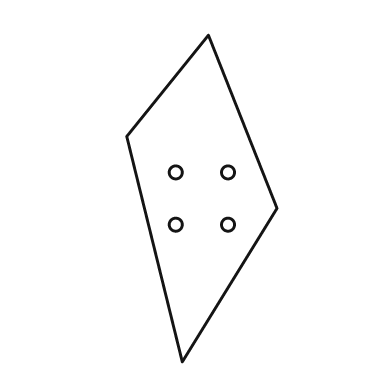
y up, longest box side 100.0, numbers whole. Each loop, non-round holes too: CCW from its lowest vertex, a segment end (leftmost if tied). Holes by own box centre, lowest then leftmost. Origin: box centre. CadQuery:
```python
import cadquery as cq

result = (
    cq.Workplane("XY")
    .moveTo(-6.0, -50.0)
    .lineTo(23.0, -3.0)
    .lineTo(2.0, 50.0)
    .lineTo(-23.0, 19.0)
    .close()
    .moveTo(-8.0, -8.0)
    .circle(2.0)
    .moveTo(8.0, -8.0)
    .circle(2.0)
    .moveTo(-8.0, 8.0)
    .circle(2.0)
    .moveTo(8.0, 8.0)
    .circle(2.0)
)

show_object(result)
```